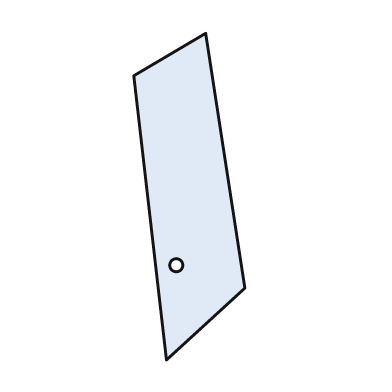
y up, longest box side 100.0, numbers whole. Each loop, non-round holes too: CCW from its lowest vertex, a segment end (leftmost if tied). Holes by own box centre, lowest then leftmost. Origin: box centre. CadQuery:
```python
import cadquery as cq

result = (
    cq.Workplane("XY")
    .moveTo(-7.0, -50.0)
    .lineTo(17.0, -28.0)
    .lineTo(5.0, 50.0)
    .lineTo(-17.0, 37.0)
    .close()
    .moveTo(-4.0, -21.0)
    .circle(2.0)
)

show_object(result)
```